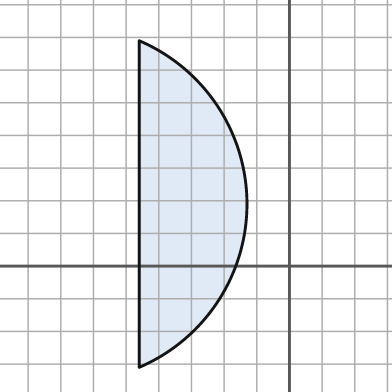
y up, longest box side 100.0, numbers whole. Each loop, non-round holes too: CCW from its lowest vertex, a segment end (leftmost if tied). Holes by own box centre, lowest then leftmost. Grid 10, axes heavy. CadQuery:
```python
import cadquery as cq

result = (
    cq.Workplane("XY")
    .moveTo(-46.0, -31.0)
    .threePointArc((-13.0, 19.0), (-46.0, 69.0))
    .close()
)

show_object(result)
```